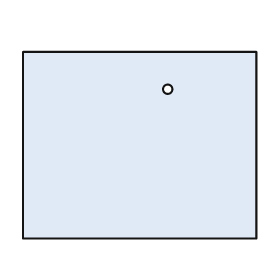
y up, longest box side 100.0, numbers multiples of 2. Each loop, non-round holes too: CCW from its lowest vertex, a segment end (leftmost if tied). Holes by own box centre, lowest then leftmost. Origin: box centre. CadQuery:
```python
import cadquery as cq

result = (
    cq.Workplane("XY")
    .moveTo(-50.0, -40.0)
    .lineTo(50.0, -40.0)
    .lineTo(50.0, 40.0)
    .lineTo(-50.0, 40.0)
    .close()
    .moveTo(12.0, 24.0)
    .circle(2.0)
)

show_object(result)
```